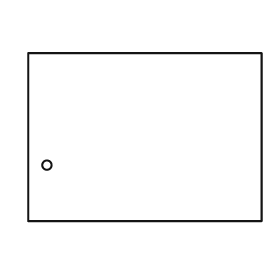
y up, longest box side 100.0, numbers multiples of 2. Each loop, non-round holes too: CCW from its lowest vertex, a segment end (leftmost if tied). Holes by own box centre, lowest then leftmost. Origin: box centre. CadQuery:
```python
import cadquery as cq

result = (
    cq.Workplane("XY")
    .moveTo(-50.0, -36.0)
    .lineTo(50.0, -36.0)
    .lineTo(50.0, 36.0)
    .lineTo(-50.0, 36.0)
    .close()
    .moveTo(-42.0, -12.0)
    .circle(2.0)
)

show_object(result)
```